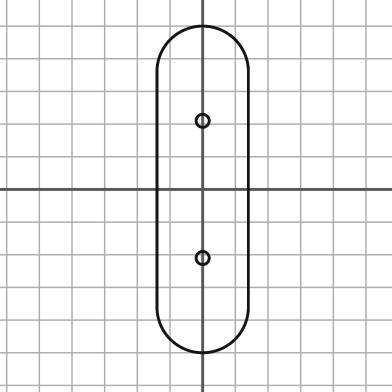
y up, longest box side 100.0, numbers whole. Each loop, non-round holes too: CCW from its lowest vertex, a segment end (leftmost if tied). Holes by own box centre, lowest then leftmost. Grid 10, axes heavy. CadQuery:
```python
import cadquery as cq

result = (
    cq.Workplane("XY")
    .moveTo(-14.0, -36.0)
    .threePointArc((0.0, -50.0), (14.0, -36.0))
    .lineTo(14.0, 36.0)
    .threePointArc((0.0, 50.0), (-14.0, 36.0))
    .close()
    .moveTo(0.0, -21.0)
    .circle(2.0)
    .moveTo(0.0, 21.0)
    .circle(2.0)
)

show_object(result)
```